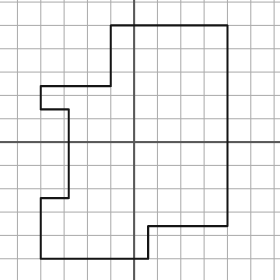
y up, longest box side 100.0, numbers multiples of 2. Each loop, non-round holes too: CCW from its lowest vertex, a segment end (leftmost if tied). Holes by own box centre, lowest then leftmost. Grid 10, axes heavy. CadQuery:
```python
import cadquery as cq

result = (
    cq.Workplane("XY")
    .moveTo(-40.0, -50.0)
    .lineTo(6.0, -50.0)
    .lineTo(6.0, -36.0)
    .lineTo(40.0, -36.0)
    .lineTo(40.0, 50.0)
    .lineTo(-10.0, 50.0)
    .lineTo(-10.0, 24.0)
    .lineTo(-40.0, 24.0)
    .lineTo(-40.0, 14.0)
    .lineTo(-28.0, 14.0)
    .lineTo(-28.0, -24.0)
    .lineTo(-40.0, -24.0)
    .close()
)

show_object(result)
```